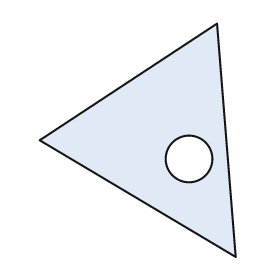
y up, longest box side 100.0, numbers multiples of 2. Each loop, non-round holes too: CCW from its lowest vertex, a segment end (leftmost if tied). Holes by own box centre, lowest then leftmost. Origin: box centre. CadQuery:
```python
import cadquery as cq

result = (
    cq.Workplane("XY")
    .moveTo(42.0, -50.0)
    .lineTo(34.0, 50.0)
    .lineTo(-42.0, 0.0)
    .close()
    .moveTo(22.0, -8.0)
    .circle(10.0)
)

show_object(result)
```